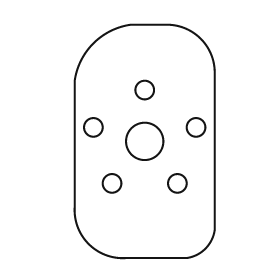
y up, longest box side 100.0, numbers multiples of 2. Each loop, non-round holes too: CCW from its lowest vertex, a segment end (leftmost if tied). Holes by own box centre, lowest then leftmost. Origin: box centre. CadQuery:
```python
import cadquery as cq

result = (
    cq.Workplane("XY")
    .moveTo(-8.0, -50.0)
    .lineTo(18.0, -50.0)
    .threePointArc((26.0, -46.0), (30.0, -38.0))
    .lineTo(30.0, 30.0)
    .threePointArc((24.0, 44.0), (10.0, 50.0))
    .lineTo(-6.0, 50.0)
    .threePointArc((-22.0, 42.0), (-30.0, 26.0))
    .lineTo(-30.0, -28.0)
    .threePointArc((-24.0, -44.0), (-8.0, -50.0))
    .close()
    .moveTo(-14.0, -18.0)
    .circle(4.0)
    .moveTo(14.0, -18.0)
    .circle(4.0)
    .moveTo(0.0, 0.0)
    .circle(8.0)
    .moveTo(-22.0, 6.0)
    .circle(4.0)
    .moveTo(22.0, 6.0)
    .circle(4.0)
    .moveTo(0.0, 22.0)
    .circle(4.0)
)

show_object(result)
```